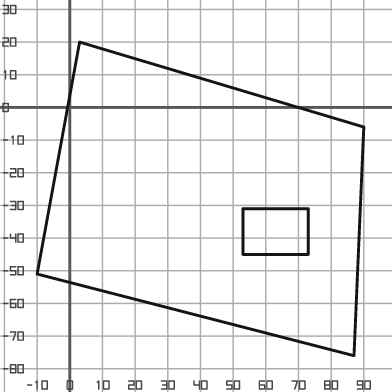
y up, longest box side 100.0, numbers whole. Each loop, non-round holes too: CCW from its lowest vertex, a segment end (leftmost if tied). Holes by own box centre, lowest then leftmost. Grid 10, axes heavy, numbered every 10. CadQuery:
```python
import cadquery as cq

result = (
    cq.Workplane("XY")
    .moveTo(87.0, -76.0)
    .lineTo(90.0, -6.0)
    .lineTo(3.0, 20.0)
    .lineTo(-10.0, -51.0)
    .close()
    .moveTo(53.0, -45.0)
    .lineTo(73.0, -45.0)
    .lineTo(73.0, -31.0)
    .lineTo(53.0, -31.0)
    .close()
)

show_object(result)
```